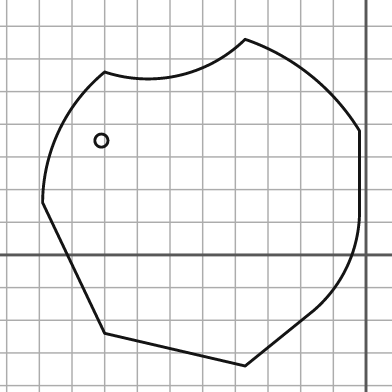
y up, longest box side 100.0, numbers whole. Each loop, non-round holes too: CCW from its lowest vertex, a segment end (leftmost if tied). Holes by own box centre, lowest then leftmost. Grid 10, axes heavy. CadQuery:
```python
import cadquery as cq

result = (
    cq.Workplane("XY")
    .moveTo(-37.0, -34.0)
    .lineTo(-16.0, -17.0)
    .threePointArc((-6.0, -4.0), (-2.0, 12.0))
    .lineTo(-2.0, 38.0)
    .threePointArc((-17.0, 55.0), (-37.0, 66.0))
    .threePointArc((-57.0, 55.0), (-80.0, 56.0))
    .threePointArc((-94.0, 38.0), (-99.0, 16.0))
    .lineTo(-80.0, -24.0)
    .close()
    .moveTo(-81.0, 35.0)
    .circle(2.0)
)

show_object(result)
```